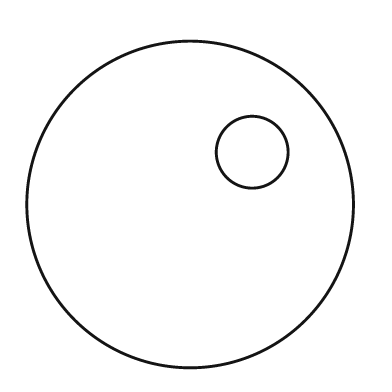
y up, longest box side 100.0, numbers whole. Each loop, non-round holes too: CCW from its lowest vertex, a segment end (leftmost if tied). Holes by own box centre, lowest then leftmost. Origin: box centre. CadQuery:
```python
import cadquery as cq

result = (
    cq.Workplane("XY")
    .moveTo(0.0, 0.0)
    .circle(50.0)
    .moveTo(19.0, 16.0)
    .circle(11.0)
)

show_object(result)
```